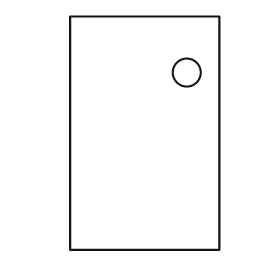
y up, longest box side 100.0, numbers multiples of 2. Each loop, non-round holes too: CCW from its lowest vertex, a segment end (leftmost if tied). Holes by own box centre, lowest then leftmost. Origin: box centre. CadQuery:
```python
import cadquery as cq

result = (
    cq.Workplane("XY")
    .moveTo(-32.0, -50.0)
    .lineTo(32.0, -50.0)
    .lineTo(32.0, 50.0)
    .lineTo(-32.0, 50.0)
    .close()
    .moveTo(18.0, 26.0)
    .circle(6.0)
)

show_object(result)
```